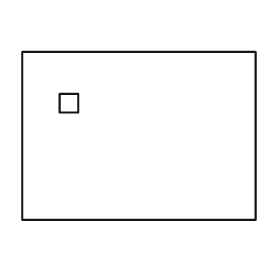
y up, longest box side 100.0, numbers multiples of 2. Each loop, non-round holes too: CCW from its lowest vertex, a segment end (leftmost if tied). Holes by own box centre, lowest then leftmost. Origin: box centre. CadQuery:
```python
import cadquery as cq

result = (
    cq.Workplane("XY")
    .moveTo(-50.0, -36.0)
    .lineTo(50.0, -36.0)
    .lineTo(50.0, 36.0)
    .lineTo(-50.0, 36.0)
    .close()
    .moveTo(-34.0, 10.0)
    .lineTo(-26.0, 10.0)
    .lineTo(-26.0, 18.0)
    .lineTo(-34.0, 18.0)
    .close()
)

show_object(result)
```